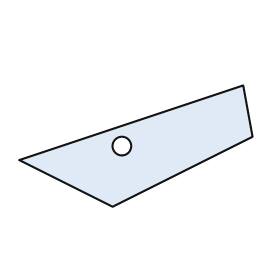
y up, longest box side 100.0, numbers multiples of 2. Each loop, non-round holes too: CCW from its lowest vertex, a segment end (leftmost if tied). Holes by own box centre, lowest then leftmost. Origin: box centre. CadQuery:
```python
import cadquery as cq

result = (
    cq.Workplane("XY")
    .moveTo(-10.0, -26.0)
    .lineTo(50.0, 4.0)
    .lineTo(46.0, 26.0)
    .lineTo(-50.0, -6.0)
    .close()
    .moveTo(-6.0, 0.0)
    .circle(4.0)
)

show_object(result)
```